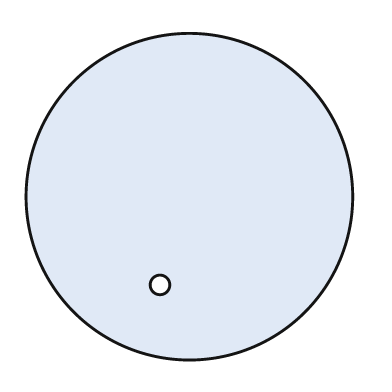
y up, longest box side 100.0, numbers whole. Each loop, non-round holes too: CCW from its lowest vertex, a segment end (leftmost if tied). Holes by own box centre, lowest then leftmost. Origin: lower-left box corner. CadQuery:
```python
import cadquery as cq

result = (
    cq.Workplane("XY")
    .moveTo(50.0, 50.0)
    .circle(50.0)
    .moveTo(41.0, 23.0)
    .circle(3.0)
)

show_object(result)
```